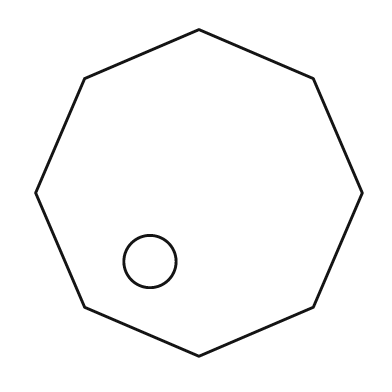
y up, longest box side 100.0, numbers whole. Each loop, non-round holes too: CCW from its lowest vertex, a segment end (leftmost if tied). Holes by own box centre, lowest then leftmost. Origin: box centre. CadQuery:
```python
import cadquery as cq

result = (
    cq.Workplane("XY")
    .moveTo(0.0, -50.0)
    .lineTo(35.0, -35.0)
    .lineTo(50.0, 0.0)
    .lineTo(35.0, 35.0)
    .lineTo(0.0, 50.0)
    .lineTo(-35.0, 35.0)
    .lineTo(-50.0, 0.0)
    .lineTo(-35.0, -35.0)
    .close()
    .moveTo(-15.0, -21.0)
    .circle(8.0)
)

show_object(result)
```